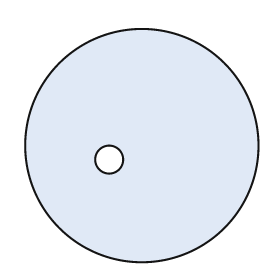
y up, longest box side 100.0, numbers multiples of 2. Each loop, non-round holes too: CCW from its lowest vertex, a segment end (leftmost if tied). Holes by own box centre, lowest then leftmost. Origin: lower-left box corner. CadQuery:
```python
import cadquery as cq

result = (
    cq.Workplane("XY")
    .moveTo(50.0, 50.0)
    .circle(50.0)
    .moveTo(36.0, 44.0)
    .circle(6.0)
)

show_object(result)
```